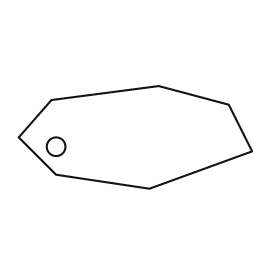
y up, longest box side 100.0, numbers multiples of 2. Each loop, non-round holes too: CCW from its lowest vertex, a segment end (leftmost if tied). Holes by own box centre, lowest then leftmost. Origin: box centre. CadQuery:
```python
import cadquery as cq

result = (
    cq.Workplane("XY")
    .moveTo(6.0, -22.0)
    .lineTo(50.0, -6.0)
    .lineTo(40.0, 14.0)
    .lineTo(10.0, 22.0)
    .lineTo(-36.0, 16.0)
    .lineTo(-50.0, 0.0)
    .lineTo(-34.0, -16.0)
    .close()
    .moveTo(-34.0, -4.0)
    .circle(4.0)
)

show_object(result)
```